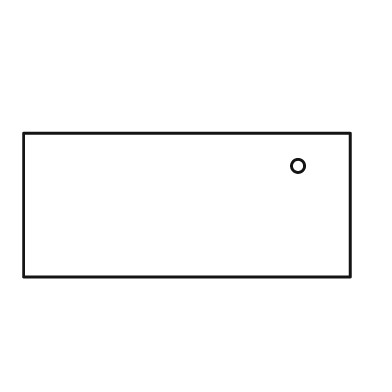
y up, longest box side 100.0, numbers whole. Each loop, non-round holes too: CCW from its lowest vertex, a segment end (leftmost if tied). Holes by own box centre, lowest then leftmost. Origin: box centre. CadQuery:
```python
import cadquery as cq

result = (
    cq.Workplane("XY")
    .moveTo(-50.0, -22.0)
    .lineTo(50.0, -22.0)
    .lineTo(50.0, 22.0)
    .lineTo(-50.0, 22.0)
    .close()
    .moveTo(34.0, 12.0)
    .circle(2.0)
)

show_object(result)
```